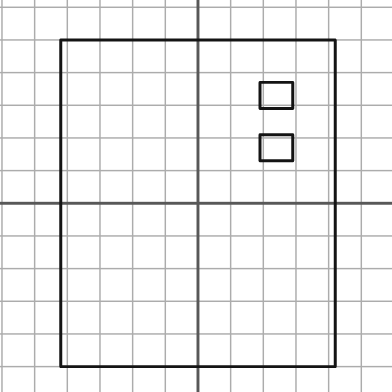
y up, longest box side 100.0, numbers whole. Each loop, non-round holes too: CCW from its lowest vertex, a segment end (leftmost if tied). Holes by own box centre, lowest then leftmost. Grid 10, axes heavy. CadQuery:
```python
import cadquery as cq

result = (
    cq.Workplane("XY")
    .moveTo(-42.0, -50.0)
    .lineTo(42.0, -50.0)
    .lineTo(42.0, 50.0)
    .lineTo(-42.0, 50.0)
    .close()
    .moveTo(19.0, 13.0)
    .lineTo(29.0, 13.0)
    .lineTo(29.0, 21.0)
    .lineTo(19.0, 21.0)
    .close()
    .moveTo(19.0, 29.0)
    .lineTo(29.0, 29.0)
    .lineTo(29.0, 37.0)
    .lineTo(19.0, 37.0)
    .close()
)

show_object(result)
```